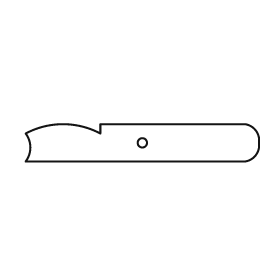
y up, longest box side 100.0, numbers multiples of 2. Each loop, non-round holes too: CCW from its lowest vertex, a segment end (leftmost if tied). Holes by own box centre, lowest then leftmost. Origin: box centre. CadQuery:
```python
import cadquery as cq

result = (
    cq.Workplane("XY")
    .moveTo(-50.0, -8.0)
    .lineTo(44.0, -8.0)
    .threePointArc((48.0, -6.0), (50.0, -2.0))
    .lineTo(50.0, 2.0)
    .threePointArc((48.0, 6.0), (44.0, 8.0))
    .lineTo(-18.0, 8.0)
    .lineTo(-18.0, 4.0)
    .threePointArc((-34.0, 8.0), (-50.0, 4.0))
    .threePointArc((-48.0, -2.0), (-50.0, -8.0))
    .close()
    .moveTo(0.0, 0.0)
    .circle(2.0)
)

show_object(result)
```